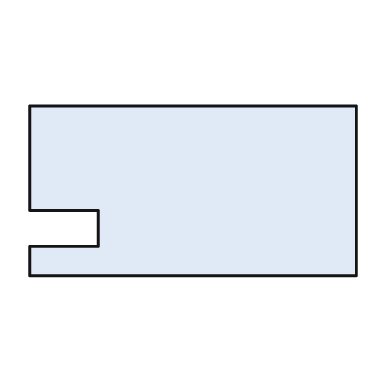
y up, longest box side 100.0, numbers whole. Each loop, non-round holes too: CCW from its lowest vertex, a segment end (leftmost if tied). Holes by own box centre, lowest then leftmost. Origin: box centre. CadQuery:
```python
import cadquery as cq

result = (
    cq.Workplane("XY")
    .moveTo(-50.0, -26.0)
    .lineTo(50.0, -26.0)
    .lineTo(50.0, 26.0)
    .lineTo(-50.0, 26.0)
    .lineTo(-50.0, -6.0)
    .lineTo(-29.0, -6.0)
    .lineTo(-29.0, -17.0)
    .lineTo(-50.0, -17.0)
    .close()
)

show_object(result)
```